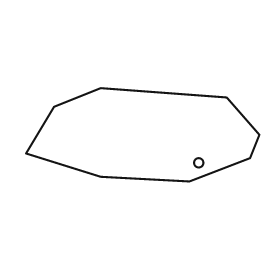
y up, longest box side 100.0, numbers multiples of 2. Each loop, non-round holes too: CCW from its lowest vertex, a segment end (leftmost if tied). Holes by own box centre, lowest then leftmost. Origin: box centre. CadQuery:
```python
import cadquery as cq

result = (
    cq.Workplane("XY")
    .moveTo(20.0, -20.0)
    .lineTo(46.0, -10.0)
    .lineTo(50.0, 0.0)
    .lineTo(36.0, 16.0)
    .lineTo(-18.0, 20.0)
    .lineTo(-38.0, 12.0)
    .lineTo(-50.0, -8.0)
    .lineTo(-18.0, -18.0)
    .close()
    .moveTo(24.0, -12.0)
    .circle(2.0)
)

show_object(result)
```